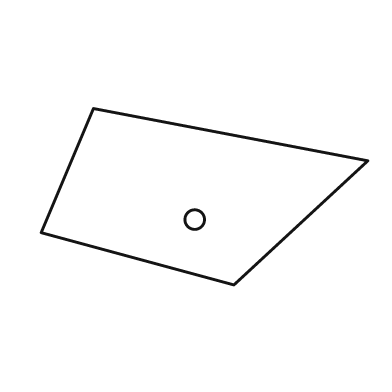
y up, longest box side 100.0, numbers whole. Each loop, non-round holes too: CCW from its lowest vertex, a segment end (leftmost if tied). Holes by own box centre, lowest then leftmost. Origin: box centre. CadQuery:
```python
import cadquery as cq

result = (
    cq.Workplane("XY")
    .moveTo(9.0, -27.0)
    .lineTo(50.0, 11.0)
    .lineTo(-34.0, 27.0)
    .lineTo(-50.0, -11.0)
    .close()
    .moveTo(-3.0, -7.0)
    .circle(3.0)
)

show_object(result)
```